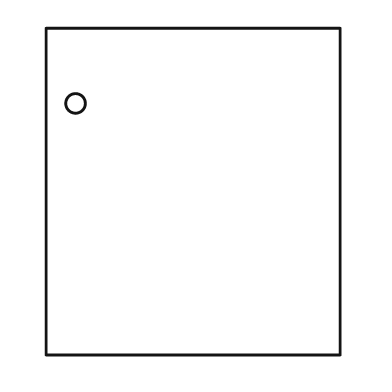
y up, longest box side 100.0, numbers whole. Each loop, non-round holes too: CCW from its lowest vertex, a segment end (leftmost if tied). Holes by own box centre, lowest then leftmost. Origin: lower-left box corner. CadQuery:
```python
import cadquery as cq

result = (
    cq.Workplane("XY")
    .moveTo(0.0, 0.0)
    .lineTo(90.0, 0.0)
    .lineTo(90.0, 100.0)
    .lineTo(0.0, 100.0)
    .close()
    .moveTo(9.0, 77.0)
    .circle(3.0)
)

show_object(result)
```